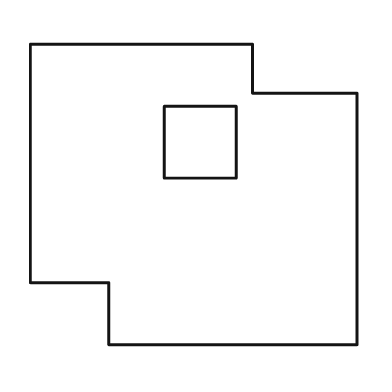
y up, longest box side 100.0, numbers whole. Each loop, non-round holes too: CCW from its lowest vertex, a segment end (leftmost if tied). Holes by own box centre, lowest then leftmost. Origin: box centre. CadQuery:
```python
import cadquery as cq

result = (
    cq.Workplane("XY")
    .moveTo(-26.0, -46.0)
    .lineTo(50.0, -46.0)
    .lineTo(50.0, 31.0)
    .lineTo(18.0, 31.0)
    .lineTo(18.0, 46.0)
    .lineTo(-50.0, 46.0)
    .lineTo(-50.0, -27.0)
    .lineTo(-26.0, -27.0)
    .close()
    .moveTo(-9.0, 5.0)
    .lineTo(13.0, 5.0)
    .lineTo(13.0, 27.0)
    .lineTo(-9.0, 27.0)
    .close()
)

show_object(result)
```